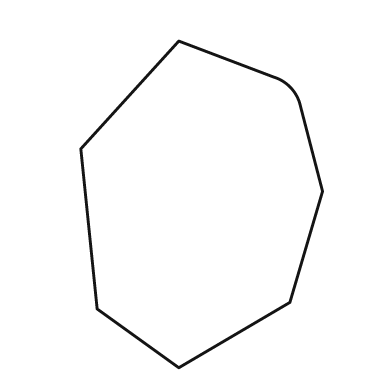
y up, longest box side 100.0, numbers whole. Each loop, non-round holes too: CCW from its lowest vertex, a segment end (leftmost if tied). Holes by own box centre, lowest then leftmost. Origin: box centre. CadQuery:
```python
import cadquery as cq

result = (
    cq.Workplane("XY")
    .moveTo(-7.0, -50.0)
    .lineTo(27.0, -30.0)
    .lineTo(37.0, 4.0)
    .lineTo(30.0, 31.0)
    .threePointArc((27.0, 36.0), (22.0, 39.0))
    .lineTo(-7.0, 50.0)
    .lineTo(-37.0, 17.0)
    .lineTo(-32.0, -32.0)
    .close()
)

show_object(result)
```